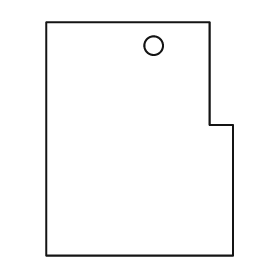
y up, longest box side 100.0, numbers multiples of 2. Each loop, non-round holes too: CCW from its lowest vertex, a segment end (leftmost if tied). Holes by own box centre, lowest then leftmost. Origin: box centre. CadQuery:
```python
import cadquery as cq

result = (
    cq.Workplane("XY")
    .moveTo(-40.0, -50.0)
    .lineTo(40.0, -50.0)
    .lineTo(40.0, 6.0)
    .lineTo(30.0, 6.0)
    .lineTo(30.0, 50.0)
    .lineTo(-40.0, 50.0)
    .close()
    .moveTo(6.0, 40.0)
    .circle(4.0)
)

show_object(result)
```